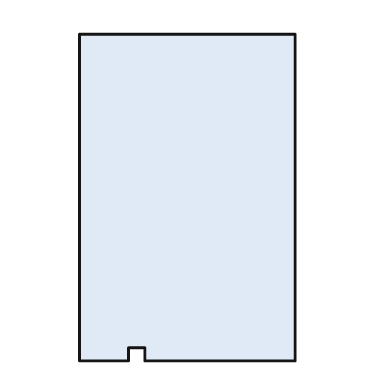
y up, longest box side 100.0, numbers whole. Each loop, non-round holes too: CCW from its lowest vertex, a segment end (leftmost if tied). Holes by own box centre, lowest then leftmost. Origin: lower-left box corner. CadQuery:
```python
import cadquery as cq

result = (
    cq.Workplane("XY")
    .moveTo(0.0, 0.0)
    .lineTo(15.0, 0.0)
    .lineTo(15.0, 4.0)
    .lineTo(20.0, 4.0)
    .lineTo(20.0, 0.0)
    .lineTo(66.0, 0.0)
    .lineTo(66.0, 100.0)
    .lineTo(0.0, 100.0)
    .close()
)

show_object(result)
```